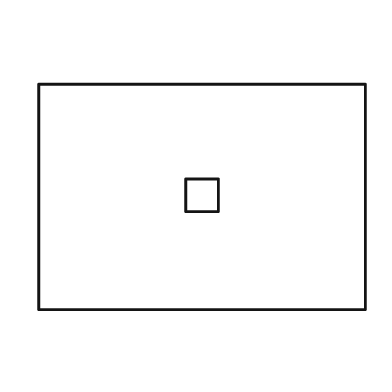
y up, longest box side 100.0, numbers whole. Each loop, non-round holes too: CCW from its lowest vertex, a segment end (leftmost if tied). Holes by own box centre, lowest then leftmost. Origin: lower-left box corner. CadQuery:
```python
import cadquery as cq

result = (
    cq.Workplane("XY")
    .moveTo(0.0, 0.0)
    .lineTo(100.0, 0.0)
    .lineTo(100.0, 69.0)
    .lineTo(0.0, 69.0)
    .close()
    .moveTo(45.0, 30.0)
    .lineTo(55.0, 30.0)
    .lineTo(55.0, 40.0)
    .lineTo(45.0, 40.0)
    .close()
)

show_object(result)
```